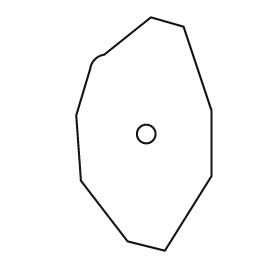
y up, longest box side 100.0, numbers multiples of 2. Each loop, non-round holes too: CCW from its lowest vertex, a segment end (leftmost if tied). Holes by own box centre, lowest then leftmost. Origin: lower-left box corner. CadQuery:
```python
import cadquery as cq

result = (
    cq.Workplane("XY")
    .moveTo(38.0, 0.0)
    .lineTo(58.0, 32.0)
    .lineTo(58.0, 60.0)
    .lineTo(46.0, 96.0)
    .lineTo(32.0, 100.0)
    .lineTo(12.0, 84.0)
    .threePointArc((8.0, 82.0), (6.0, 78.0))
    .lineTo(0.0, 58.0)
    .lineTo(2.0, 30.0)
    .lineTo(22.0, 4.0)
    .close()
    .moveTo(30.0, 50.0)
    .circle(4.0)
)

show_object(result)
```